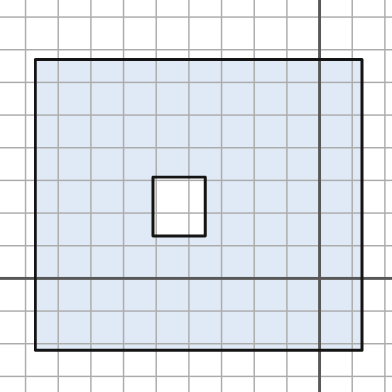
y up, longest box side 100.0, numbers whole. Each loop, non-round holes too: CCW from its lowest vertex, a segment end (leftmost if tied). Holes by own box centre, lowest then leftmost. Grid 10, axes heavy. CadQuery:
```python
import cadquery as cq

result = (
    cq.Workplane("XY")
    .moveTo(-87.0, -22.0)
    .lineTo(13.0, -22.0)
    .lineTo(13.0, 67.0)
    .lineTo(-87.0, 67.0)
    .close()
    .moveTo(-51.0, 13.0)
    .lineTo(-35.0, 13.0)
    .lineTo(-35.0, 31.0)
    .lineTo(-51.0, 31.0)
    .close()
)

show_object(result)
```